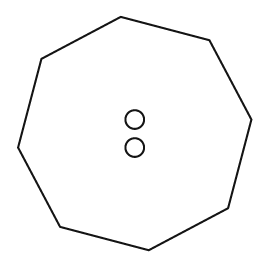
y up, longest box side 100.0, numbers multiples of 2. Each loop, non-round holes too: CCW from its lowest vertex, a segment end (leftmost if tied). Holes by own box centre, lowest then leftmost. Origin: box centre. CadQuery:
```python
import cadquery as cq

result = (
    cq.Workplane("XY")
    .moveTo(6.0, -50.0)
    .lineTo(40.0, -32.0)
    .lineTo(50.0, 6.0)
    .lineTo(32.0, 40.0)
    .lineTo(-6.0, 50.0)
    .lineTo(-40.0, 32.0)
    .lineTo(-50.0, -6.0)
    .lineTo(-32.0, -40.0)
    .close()
    .moveTo(0.0, -6.0)
    .circle(4.0)
    .moveTo(0.0, 6.0)
    .circle(4.0)
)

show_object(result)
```